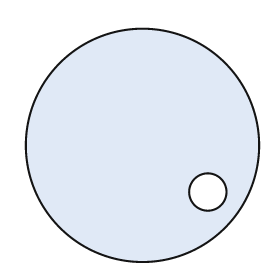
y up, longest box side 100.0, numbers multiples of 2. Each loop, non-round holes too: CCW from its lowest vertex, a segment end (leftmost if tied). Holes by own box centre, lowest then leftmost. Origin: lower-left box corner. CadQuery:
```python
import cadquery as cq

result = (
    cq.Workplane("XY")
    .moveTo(50.0, 50.0)
    .circle(50.0)
    .moveTo(78.0, 30.0)
    .circle(8.0)
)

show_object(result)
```